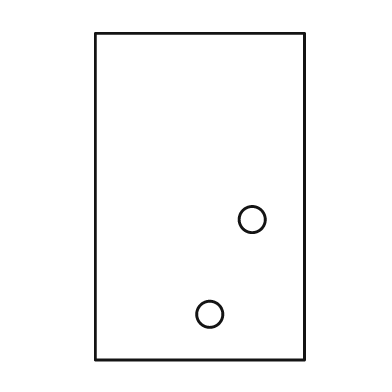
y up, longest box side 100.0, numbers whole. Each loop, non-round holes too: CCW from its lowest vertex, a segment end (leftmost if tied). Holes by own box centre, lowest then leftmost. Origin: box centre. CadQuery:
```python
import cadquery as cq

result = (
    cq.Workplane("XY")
    .moveTo(-32.0, -50.0)
    .lineTo(32.0, -50.0)
    .lineTo(32.0, 50.0)
    .lineTo(-32.0, 50.0)
    .close()
    .moveTo(3.0, -36.0)
    .circle(4.0)
    .moveTo(16.0, -7.0)
    .circle(4.0)
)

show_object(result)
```